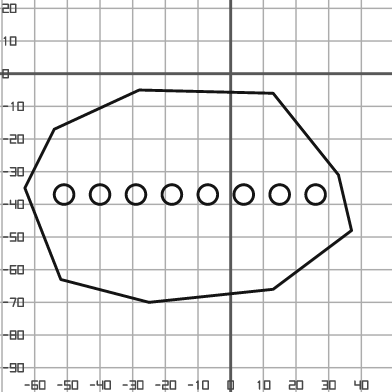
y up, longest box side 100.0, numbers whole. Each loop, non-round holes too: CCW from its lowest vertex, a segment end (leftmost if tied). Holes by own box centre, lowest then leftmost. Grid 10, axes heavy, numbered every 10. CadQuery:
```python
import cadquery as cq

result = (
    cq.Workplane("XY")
    .moveTo(-25.0, -70.0)
    .lineTo(13.0, -66.0)
    .lineTo(37.0, -48.0)
    .lineTo(33.0, -31.0)
    .lineTo(13.0, -6.0)
    .lineTo(-28.0, -5.0)
    .lineTo(-54.0, -17.0)
    .lineTo(-63.0, -35.0)
    .lineTo(-52.0, -63.0)
    .close()
    .moveTo(-51.0, -37.0)
    .circle(3.0)
    .moveTo(-40.0, -37.0)
    .circle(3.0)
    .moveTo(-29.0, -37.0)
    .circle(3.0)
    .moveTo(-18.0, -37.0)
    .circle(3.0)
    .moveTo(-7.0, -37.0)
    .circle(3.0)
    .moveTo(4.0, -37.0)
    .circle(3.0)
    .moveTo(15.0, -37.0)
    .circle(3.0)
    .moveTo(26.0, -37.0)
    .circle(3.0)
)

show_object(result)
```